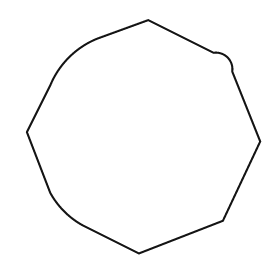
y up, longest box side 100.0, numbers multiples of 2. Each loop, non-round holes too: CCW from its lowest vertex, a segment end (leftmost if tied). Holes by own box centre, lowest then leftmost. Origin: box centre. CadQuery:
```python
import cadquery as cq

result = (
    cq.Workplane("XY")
    .moveTo(-2.0, -50.0)
    .lineTo(34.0, -36.0)
    .lineTo(50.0, -2.0)
    .lineTo(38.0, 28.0)
    .threePointArc((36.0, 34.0), (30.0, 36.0))
    .lineTo(2.0, 50.0)
    .lineTo(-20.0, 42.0)
    .threePointArc((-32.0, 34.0), (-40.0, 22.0))
    .lineTo(-50.0, 2.0)
    .lineTo(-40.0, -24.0)
    .threePointArc((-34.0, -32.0), (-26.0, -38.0))
    .close()
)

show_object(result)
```